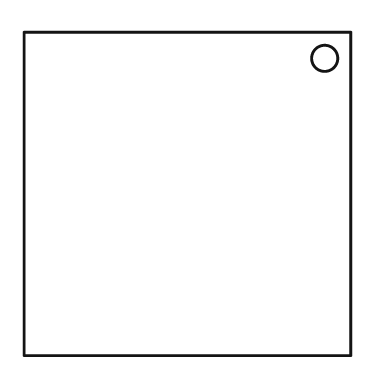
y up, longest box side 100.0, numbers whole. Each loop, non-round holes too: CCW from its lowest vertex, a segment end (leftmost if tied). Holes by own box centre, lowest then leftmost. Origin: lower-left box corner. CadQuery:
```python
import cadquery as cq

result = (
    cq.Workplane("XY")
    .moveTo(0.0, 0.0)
    .lineTo(100.0, 0.0)
    .lineTo(100.0, 99.0)
    .lineTo(0.0, 99.0)
    .close()
    .moveTo(92.0, 91.0)
    .circle(4.0)
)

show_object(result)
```